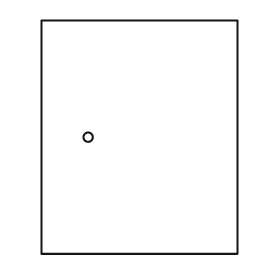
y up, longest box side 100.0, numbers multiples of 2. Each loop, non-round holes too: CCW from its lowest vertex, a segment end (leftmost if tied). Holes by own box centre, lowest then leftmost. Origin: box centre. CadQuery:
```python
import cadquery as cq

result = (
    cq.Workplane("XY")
    .moveTo(-42.0, -50.0)
    .lineTo(42.0, -50.0)
    .lineTo(42.0, 50.0)
    .lineTo(-42.0, 50.0)
    .close()
    .moveTo(-22.0, 0.0)
    .circle(2.0)
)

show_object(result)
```